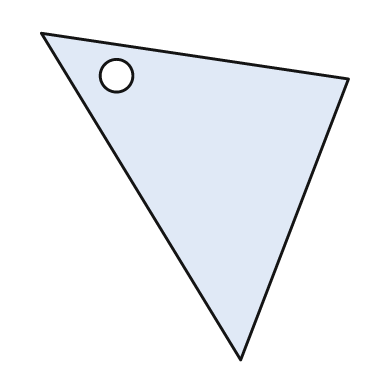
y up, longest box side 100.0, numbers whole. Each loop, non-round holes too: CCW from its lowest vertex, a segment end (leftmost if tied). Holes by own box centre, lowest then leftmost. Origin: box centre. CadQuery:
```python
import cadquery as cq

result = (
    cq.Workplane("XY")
    .moveTo(14.0, -50.0)
    .lineTo(47.0, 36.0)
    .lineTo(-47.0, 50.0)
    .close()
    .moveTo(-24.0, 37.0)
    .circle(5.0)
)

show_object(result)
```